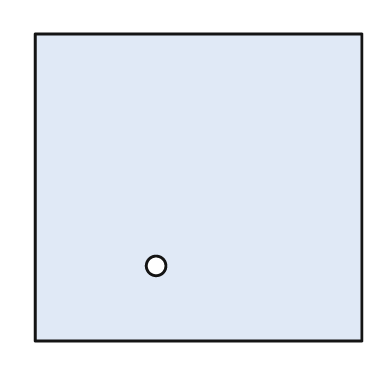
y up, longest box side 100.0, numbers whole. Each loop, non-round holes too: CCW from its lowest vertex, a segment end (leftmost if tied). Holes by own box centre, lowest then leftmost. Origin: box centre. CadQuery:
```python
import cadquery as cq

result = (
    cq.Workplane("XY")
    .moveTo(-50.0, -47.0)
    .lineTo(50.0, -47.0)
    .lineTo(50.0, 47.0)
    .lineTo(-50.0, 47.0)
    .close()
    .moveTo(-13.0, -24.0)
    .circle(3.0)
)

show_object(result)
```